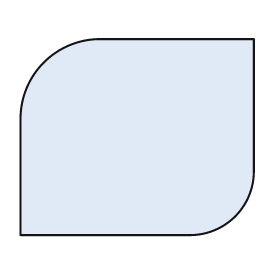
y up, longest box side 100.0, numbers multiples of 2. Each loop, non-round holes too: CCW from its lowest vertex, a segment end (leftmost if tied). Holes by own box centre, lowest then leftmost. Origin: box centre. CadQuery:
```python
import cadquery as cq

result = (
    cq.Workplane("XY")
    .moveTo(-50.0, -42.0)
    .lineTo(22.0, -42.0)
    .threePointArc((42.0, -34.0), (50.0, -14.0))
    .lineTo(50.0, 42.0)
    .lineTo(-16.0, 42.0)
    .threePointArc((-40.0, 32.0), (-50.0, 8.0))
    .close()
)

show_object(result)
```